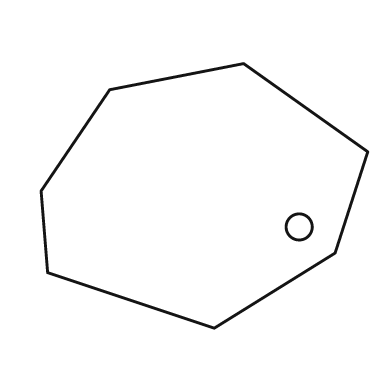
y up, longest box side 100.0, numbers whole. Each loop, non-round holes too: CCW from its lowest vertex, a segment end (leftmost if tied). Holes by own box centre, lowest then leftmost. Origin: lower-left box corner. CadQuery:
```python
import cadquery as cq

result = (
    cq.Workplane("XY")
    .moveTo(53.0, 0.0)
    .lineTo(90.0, 23.0)
    .lineTo(100.0, 54.0)
    .lineTo(62.0, 81.0)
    .lineTo(21.0, 73.0)
    .lineTo(0.0, 42.0)
    .lineTo(2.0, 17.0)
    .close()
    .moveTo(79.0, 31.0)
    .circle(4.0)
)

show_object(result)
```